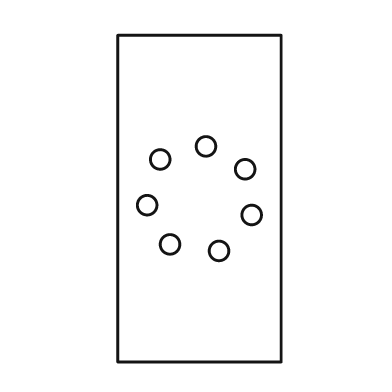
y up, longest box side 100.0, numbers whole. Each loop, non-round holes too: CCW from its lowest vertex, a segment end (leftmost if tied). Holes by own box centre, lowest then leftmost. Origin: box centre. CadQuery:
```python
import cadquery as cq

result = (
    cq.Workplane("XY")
    .moveTo(-25.0, -50.0)
    .lineTo(25.0, -50.0)
    .lineTo(25.0, 50.0)
    .lineTo(-25.0, 50.0)
    .close()
    .moveTo(6.0, -16.0)
    .circle(3.0)
    .moveTo(-9.0, -14.0)
    .circle(3.0)
    .moveTo(16.0, -5.0)
    .circle(3.0)
    .moveTo(-16.0, -2.0)
    .circle(3.0)
    .moveTo(14.0, 9.0)
    .circle(3.0)
    .moveTo(-12.0, 12.0)
    .circle(3.0)
    .moveTo(2.0, 16.0)
    .circle(3.0)
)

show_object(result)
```